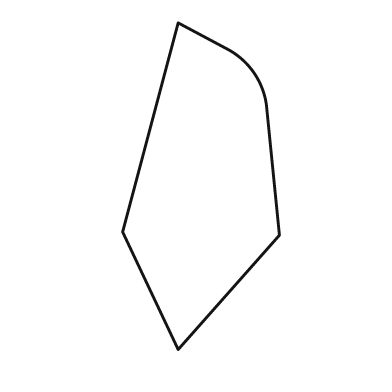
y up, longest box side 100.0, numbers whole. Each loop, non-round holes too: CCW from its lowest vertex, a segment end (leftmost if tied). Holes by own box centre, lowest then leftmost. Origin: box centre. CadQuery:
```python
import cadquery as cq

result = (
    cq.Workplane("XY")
    .moveTo(-7.0, -50.0)
    .lineTo(24.0, -15.0)
    .lineTo(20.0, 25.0)
    .threePointArc((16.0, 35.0), (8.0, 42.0))
    .lineTo(-7.0, 50.0)
    .lineTo(-24.0, -14.0)
    .close()
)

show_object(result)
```